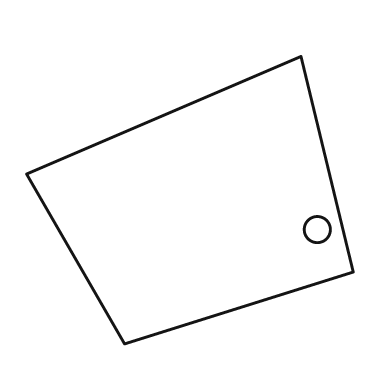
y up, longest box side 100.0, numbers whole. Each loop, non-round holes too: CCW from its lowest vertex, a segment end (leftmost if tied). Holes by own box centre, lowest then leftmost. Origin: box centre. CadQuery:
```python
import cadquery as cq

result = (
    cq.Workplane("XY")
    .moveTo(-20.0, -44.0)
    .lineTo(50.0, -22.0)
    .lineTo(34.0, 44.0)
    .lineTo(-50.0, 8.0)
    .close()
    .moveTo(39.0, -9.0)
    .circle(4.0)
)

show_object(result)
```